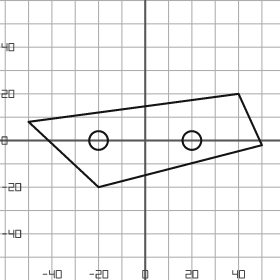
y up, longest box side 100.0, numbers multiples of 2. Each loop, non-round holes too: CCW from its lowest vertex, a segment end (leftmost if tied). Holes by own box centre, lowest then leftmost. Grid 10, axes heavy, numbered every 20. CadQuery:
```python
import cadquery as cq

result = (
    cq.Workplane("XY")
    .moveTo(-20.0, -20.0)
    .lineTo(50.0, -2.0)
    .lineTo(40.0, 20.0)
    .lineTo(-50.0, 8.0)
    .close()
    .moveTo(-20.0, 0.0)
    .circle(4.0)
    .moveTo(20.0, 0.0)
    .circle(4.0)
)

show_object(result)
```